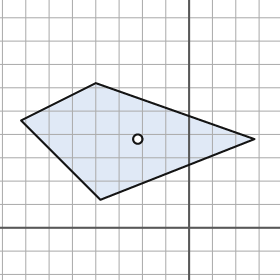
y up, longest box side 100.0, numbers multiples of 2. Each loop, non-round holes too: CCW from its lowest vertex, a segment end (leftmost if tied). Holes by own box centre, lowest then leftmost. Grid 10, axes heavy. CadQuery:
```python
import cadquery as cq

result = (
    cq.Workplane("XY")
    .moveTo(-38.0, 12.0)
    .lineTo(28.0, 38.0)
    .lineTo(-40.0, 62.0)
    .lineTo(-72.0, 46.0)
    .close()
    .moveTo(-22.0, 38.0)
    .circle(2.0)
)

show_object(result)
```